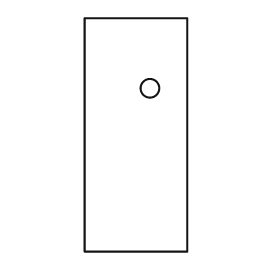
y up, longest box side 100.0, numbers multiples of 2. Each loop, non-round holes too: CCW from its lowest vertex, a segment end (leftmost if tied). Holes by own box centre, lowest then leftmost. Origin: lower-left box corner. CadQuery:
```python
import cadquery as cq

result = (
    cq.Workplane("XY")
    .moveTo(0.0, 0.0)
    .lineTo(44.0, 0.0)
    .lineTo(44.0, 100.0)
    .lineTo(0.0, 100.0)
    .close()
    .moveTo(28.0, 70.0)
    .circle(4.0)
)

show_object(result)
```